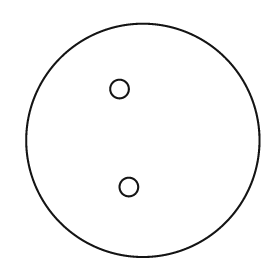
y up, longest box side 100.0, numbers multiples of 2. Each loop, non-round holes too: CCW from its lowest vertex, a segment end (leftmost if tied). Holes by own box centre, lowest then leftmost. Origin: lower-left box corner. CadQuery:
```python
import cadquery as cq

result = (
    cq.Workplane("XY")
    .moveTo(50.0, 50.0)
    .circle(50.0)
    .moveTo(44.0, 30.0)
    .circle(4.0)
    .moveTo(40.0, 72.0)
    .circle(4.0)
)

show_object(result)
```